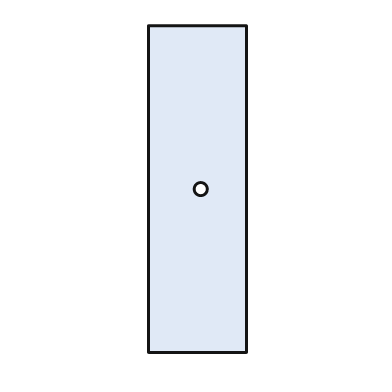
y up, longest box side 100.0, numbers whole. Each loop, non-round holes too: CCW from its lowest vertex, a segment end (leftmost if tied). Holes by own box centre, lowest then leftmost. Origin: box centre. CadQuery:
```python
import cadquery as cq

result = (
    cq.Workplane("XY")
    .moveTo(-15.0, -50.0)
    .lineTo(15.0, -50.0)
    .lineTo(15.0, 50.0)
    .lineTo(-15.0, 50.0)
    .close()
    .moveTo(1.0, 0.0)
    .circle(2.0)
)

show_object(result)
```